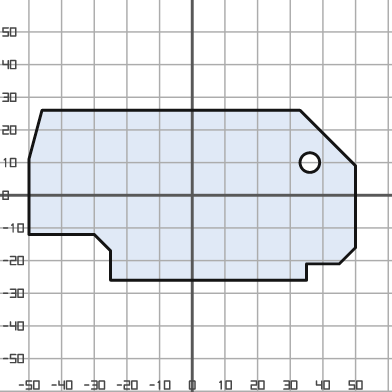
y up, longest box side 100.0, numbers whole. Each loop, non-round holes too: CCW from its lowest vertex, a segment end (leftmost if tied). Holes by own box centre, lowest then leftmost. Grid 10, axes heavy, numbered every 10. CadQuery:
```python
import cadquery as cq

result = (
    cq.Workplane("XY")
    .moveTo(-25.0, -26.0)
    .lineTo(35.0, -26.0)
    .lineTo(35.0, -21.0)
    .lineTo(45.0, -21.0)
    .lineTo(50.0, -16.0)
    .lineTo(50.0, 9.0)
    .lineTo(33.0, 26.0)
    .lineTo(-46.0, 26.0)
    .lineTo(-50.0, 11.0)
    .lineTo(-50.0, -12.0)
    .lineTo(-30.0, -12.0)
    .lineTo(-25.0, -17.0)
    .close()
    .moveTo(36.0, 10.0)
    .circle(3.0)
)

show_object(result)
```